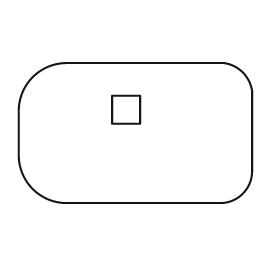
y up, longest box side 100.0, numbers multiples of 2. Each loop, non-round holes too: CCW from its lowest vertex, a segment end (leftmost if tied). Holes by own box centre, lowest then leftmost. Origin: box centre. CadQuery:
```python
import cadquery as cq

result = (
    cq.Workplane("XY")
    .moveTo(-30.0, -30.0)
    .lineTo(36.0, -30.0)
    .threePointArc((46.0, -26.0), (50.0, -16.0))
    .lineTo(50.0, 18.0)
    .threePointArc((46.0, 26.0), (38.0, 30.0))
    .lineTo(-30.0, 30.0)
    .threePointArc((-44.0, 24.0), (-50.0, 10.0))
    .lineTo(-50.0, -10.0)
    .threePointArc((-44.0, -24.0), (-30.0, -30.0))
    .close()
    .moveTo(-10.0, 4.0)
    .lineTo(2.0, 4.0)
    .lineTo(2.0, 16.0)
    .lineTo(-10.0, 16.0)
    .close()
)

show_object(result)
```